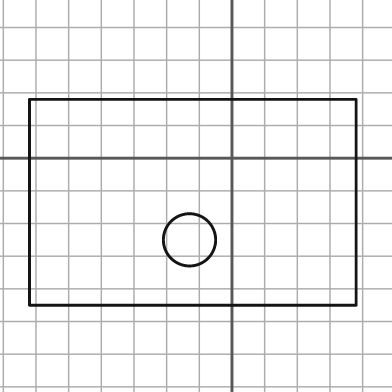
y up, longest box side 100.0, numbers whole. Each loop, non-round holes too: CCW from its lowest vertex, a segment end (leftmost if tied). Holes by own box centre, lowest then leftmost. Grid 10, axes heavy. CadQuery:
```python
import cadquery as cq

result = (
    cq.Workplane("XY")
    .moveTo(-62.0, -45.0)
    .lineTo(38.0, -45.0)
    .lineTo(38.0, 18.0)
    .lineTo(-62.0, 18.0)
    .close()
    .moveTo(-13.0, -25.0)
    .circle(8.0)
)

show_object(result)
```